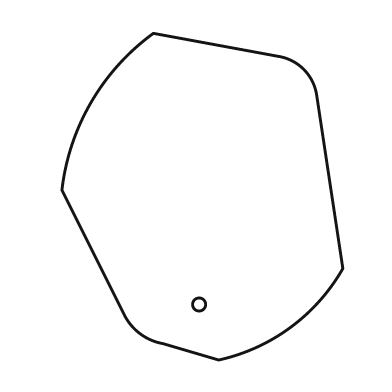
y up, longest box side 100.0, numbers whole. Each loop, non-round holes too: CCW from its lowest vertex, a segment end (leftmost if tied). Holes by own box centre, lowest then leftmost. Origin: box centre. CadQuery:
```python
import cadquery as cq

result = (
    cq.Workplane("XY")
    .moveTo(5.0, -50.0)
    .threePointArc((27.0, -40.0), (43.0, -22.0))
    .lineTo(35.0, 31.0)
    .threePointArc((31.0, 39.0), (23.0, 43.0))
    .lineTo(-15.0, 50.0)
    .threePointArc((-34.0, 29.0), (-43.0, 2.0))
    .lineTo(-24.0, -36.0)
    .threePointArc((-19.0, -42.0), (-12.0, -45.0))
    .close()
    .moveTo(-1.0, -33.0)
    .circle(2.0)
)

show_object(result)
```